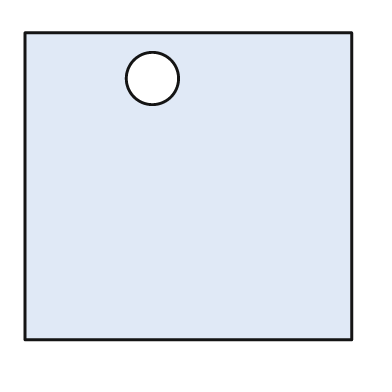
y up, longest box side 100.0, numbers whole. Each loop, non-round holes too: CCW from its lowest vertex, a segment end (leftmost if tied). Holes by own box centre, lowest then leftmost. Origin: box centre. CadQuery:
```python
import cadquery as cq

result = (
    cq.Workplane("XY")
    .moveTo(-50.0, -47.0)
    .lineTo(50.0, -47.0)
    .lineTo(50.0, 47.0)
    .lineTo(-50.0, 47.0)
    .close()
    .moveTo(-11.0, 33.0)
    .circle(8.0)
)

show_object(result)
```